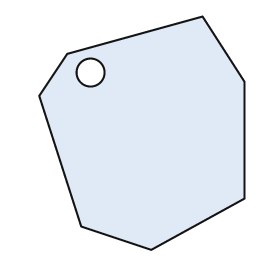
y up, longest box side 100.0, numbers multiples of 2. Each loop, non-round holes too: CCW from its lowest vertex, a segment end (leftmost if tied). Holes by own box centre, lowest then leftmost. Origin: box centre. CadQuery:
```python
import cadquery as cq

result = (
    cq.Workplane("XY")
    .moveTo(4.0, -50.0)
    .lineTo(44.0, -28.0)
    .lineTo(44.0, 22.0)
    .lineTo(26.0, 50.0)
    .lineTo(-32.0, 34.0)
    .lineTo(-44.0, 16.0)
    .lineTo(-26.0, -40.0)
    .close()
    .moveTo(-22.0, 26.0)
    .circle(6.0)
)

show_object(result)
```